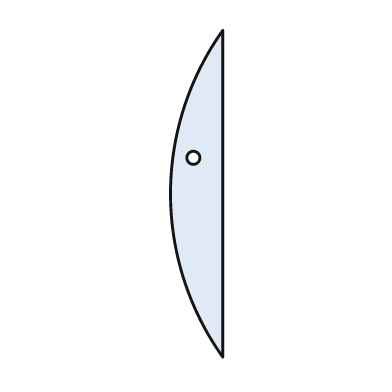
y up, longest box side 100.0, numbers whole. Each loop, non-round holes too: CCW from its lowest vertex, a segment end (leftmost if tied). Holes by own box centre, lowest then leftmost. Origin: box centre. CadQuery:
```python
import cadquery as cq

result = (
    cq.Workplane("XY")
    .moveTo(8.0, -50.0)
    .lineTo(8.0, 50.0)
    .threePointArc((-8.0, 0.0), (8.0, -50.0))
    .close()
    .moveTo(-1.0, 11.0)
    .circle(2.0)
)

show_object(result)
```